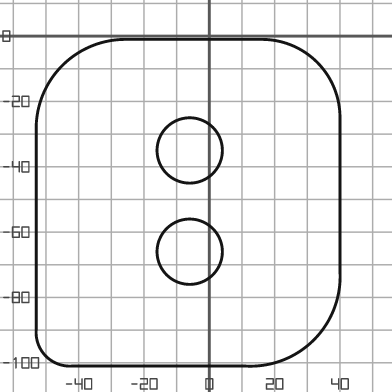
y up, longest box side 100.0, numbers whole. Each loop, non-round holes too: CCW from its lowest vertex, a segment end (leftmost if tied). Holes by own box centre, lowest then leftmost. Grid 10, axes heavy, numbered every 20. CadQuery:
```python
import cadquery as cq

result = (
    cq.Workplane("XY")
    .moveTo(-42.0, -101.0)
    .lineTo(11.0, -101.0)
    .threePointArc((32.0, -93.0), (40.0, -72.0))
    .lineTo(40.0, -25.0)
    .threePointArc((33.0, -8.0), (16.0, -1.0))
    .lineTo(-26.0, -1.0)
    .threePointArc((-45.0, -9.0), (-53.0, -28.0))
    .lineTo(-53.0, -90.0)
    .threePointArc((-50.0, -98.0), (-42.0, -101.0))
    .close()
    .moveTo(-6.0, -66.0)
    .circle(10.0)
    .moveTo(-6.0, -35.0)
    .circle(10.0)
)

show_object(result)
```